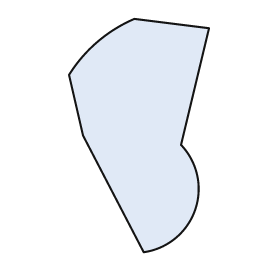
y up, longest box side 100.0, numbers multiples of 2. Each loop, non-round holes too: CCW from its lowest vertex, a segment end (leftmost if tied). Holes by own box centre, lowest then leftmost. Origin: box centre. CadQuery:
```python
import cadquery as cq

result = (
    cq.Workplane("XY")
    .moveTo(2.0, -50.0)
    .threePointArc((24.0, -32.0), (18.0, -4.0))
    .lineTo(30.0, 46.0)
    .lineTo(-2.0, 50.0)
    .threePointArc((-18.0, 40.0), (-30.0, 26.0))
    .lineTo(-24.0, 0.0)
    .close()
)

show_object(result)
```